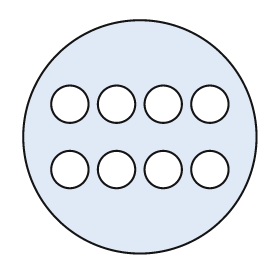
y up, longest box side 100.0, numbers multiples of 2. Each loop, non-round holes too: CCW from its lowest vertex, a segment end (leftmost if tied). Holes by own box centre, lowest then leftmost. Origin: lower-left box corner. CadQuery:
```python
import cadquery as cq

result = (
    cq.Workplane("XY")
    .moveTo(50.0, 50.0)
    .circle(50.0)
    .moveTo(20.0, 36.0)
    .circle(8.0)
    .moveTo(40.0, 36.0)
    .circle(8.0)
    .moveTo(60.0, 36.0)
    .circle(8.0)
    .moveTo(80.0, 36.0)
    .circle(8.0)
    .moveTo(20.0, 64.0)
    .circle(8.0)
    .moveTo(40.0, 64.0)
    .circle(8.0)
    .moveTo(60.0, 64.0)
    .circle(8.0)
    .moveTo(80.0, 64.0)
    .circle(8.0)
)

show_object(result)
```